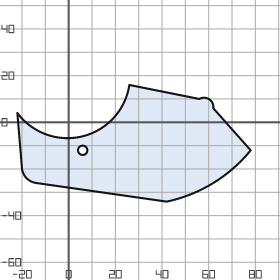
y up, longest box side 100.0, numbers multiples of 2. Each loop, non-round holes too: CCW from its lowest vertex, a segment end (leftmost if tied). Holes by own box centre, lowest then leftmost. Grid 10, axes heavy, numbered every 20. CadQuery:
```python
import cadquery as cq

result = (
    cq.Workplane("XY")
    .moveTo(42.0, -34.0)
    .threePointArc((62.0, -26.0), (78.0, -12.0))
    .lineTo(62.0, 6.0)
    .threePointArc((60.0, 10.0), (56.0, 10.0))
    .lineTo(26.0, 16.0)
    .threePointArc((6.0, -6.0), (-22.0, 4.0))
    .lineTo(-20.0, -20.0)
    .threePointArc((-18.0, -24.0), (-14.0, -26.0))
    .close()
    .moveTo(6.0, -12.0)
    .circle(2.0)
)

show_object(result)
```